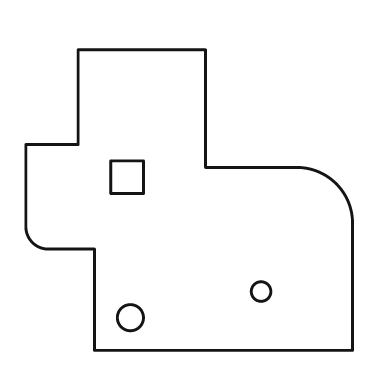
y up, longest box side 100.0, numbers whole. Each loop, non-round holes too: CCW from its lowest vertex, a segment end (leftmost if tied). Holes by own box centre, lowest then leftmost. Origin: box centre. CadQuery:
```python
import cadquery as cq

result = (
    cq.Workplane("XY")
    .moveTo(-29.0, -46.0)
    .lineTo(50.0, -46.0)
    .lineTo(50.0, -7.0)
    .threePointArc((45.0, 5.0), (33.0, 10.0))
    .lineTo(5.0, 10.0)
    .lineTo(5.0, 46.0)
    .lineTo(-34.0, 46.0)
    .lineTo(-34.0, 17.0)
    .lineTo(-50.0, 17.0)
    .lineTo(-50.0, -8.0)
    .threePointArc((-48.0, -13.0), (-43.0, -15.0))
    .lineTo(-29.0, -15.0)
    .close()
    .moveTo(-18.0, -36.0)
    .circle(4.0)
    .moveTo(22.0, -28.0)
    .circle(3.0)
    .moveTo(-24.0, 2.0)
    .lineTo(-14.0, 2.0)
    .lineTo(-14.0, 12.0)
    .lineTo(-24.0, 12.0)
    .close()
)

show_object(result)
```